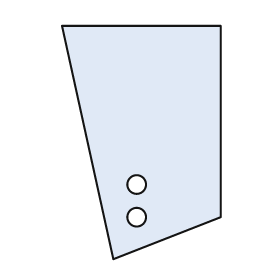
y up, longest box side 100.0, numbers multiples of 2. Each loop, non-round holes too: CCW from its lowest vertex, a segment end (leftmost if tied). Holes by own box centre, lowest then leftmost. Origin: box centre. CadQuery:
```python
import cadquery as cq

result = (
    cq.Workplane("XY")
    .moveTo(-12.0, -50.0)
    .lineTo(34.0, -32.0)
    .lineTo(34.0, 50.0)
    .lineTo(-34.0, 50.0)
    .close()
    .moveTo(-2.0, -32.0)
    .circle(4.0)
    .moveTo(-2.0, -18.0)
    .circle(4.0)
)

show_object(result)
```